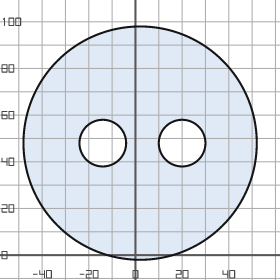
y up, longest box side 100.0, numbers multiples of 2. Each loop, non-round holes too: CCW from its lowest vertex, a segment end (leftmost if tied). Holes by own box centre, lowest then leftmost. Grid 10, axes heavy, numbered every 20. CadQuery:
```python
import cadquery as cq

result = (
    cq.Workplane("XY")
    .moveTo(2.0, 48.0)
    .circle(50.0)
    .moveTo(-14.0, 48.0)
    .circle(10.0)
    .moveTo(20.0, 48.0)
    .circle(10.0)
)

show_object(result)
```